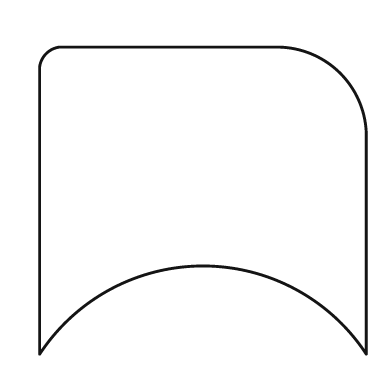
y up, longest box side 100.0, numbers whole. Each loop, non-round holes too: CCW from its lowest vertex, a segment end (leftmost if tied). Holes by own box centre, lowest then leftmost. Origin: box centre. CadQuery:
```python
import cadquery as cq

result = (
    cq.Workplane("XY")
    .moveTo(-50.0, -47.0)
    .threePointArc((0.0, -20.0), (50.0, -47.0))
    .lineTo(50.0, 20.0)
    .threePointArc((42.0, 39.0), (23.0, 47.0))
    .lineTo(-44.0, 47.0)
    .threePointArc((-48.0, 45.0), (-50.0, 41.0))
    .close()
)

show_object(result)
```